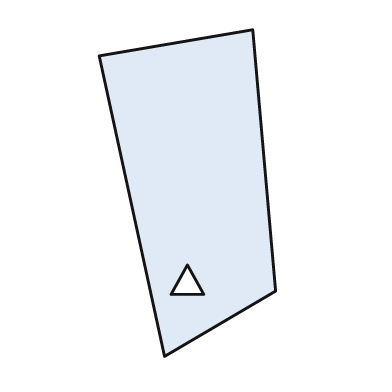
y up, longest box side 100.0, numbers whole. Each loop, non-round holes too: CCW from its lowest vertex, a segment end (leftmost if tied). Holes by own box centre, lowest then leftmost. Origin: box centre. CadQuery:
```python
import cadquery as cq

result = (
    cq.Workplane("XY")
    .moveTo(-7.0, -50.0)
    .lineTo(27.0, -30.0)
    .lineTo(20.0, 50.0)
    .lineTo(-27.0, 42.0)
    .close()
    .moveTo(-5.0, -31.0)
    .lineTo(5.0, -31.0)
    .lineTo(0.0, -22.0)
    .close()
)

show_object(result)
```